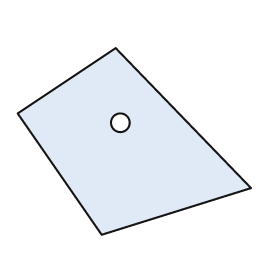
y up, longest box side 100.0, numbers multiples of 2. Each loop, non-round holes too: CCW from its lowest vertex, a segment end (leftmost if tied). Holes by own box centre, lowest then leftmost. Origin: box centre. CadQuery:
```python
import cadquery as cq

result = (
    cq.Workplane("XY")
    .moveTo(-14.0, -40.0)
    .lineTo(50.0, -20.0)
    .lineTo(-8.0, 40.0)
    .lineTo(-50.0, 12.0)
    .close()
    .moveTo(-6.0, 8.0)
    .circle(4.0)
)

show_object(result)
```